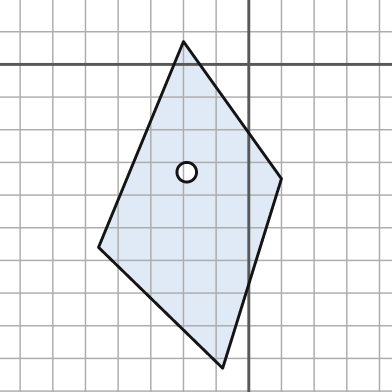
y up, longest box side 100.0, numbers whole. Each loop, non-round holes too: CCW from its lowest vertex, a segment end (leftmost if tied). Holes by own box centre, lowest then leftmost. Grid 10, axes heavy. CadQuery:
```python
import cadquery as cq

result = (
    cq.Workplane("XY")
    .moveTo(-8.0, -93.0)
    .lineTo(10.0, -35.0)
    .lineTo(-20.0, 7.0)
    .lineTo(-46.0, -56.0)
    .close()
    .moveTo(-19.0, -33.0)
    .circle(3.0)
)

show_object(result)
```